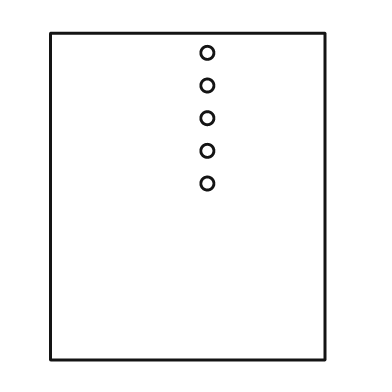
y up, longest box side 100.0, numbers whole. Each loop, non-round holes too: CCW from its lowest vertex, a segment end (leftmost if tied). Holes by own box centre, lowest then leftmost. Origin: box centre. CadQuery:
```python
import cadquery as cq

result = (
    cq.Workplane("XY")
    .moveTo(-42.0, -50.0)
    .lineTo(42.0, -50.0)
    .lineTo(42.0, 50.0)
    .lineTo(-42.0, 50.0)
    .close()
    .moveTo(6.0, 4.0)
    .circle(2.0)
    .moveTo(6.0, 14.0)
    .circle(2.0)
    .moveTo(6.0, 24.0)
    .circle(2.0)
    .moveTo(6.0, 34.0)
    .circle(2.0)
    .moveTo(6.0, 44.0)
    .circle(2.0)
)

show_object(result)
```